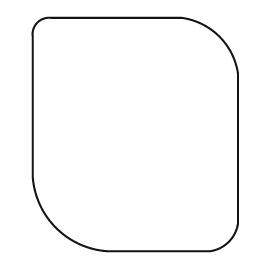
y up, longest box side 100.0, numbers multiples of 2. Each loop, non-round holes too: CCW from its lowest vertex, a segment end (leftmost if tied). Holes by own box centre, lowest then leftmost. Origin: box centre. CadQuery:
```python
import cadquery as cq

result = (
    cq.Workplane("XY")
    .moveTo(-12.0, -50.0)
    .lineTo(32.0, -50.0)
    .threePointArc((40.0, -46.0), (44.0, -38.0))
    .lineTo(44.0, 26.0)
    .threePointArc((36.0, 42.0), (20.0, 50.0))
    .lineTo(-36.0, 50.0)
    .threePointArc((-42.0, 48.0), (-44.0, 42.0))
    .lineTo(-44.0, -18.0)
    .threePointArc((-34.0, -40.0), (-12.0, -50.0))
    .close()
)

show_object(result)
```